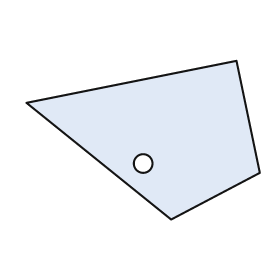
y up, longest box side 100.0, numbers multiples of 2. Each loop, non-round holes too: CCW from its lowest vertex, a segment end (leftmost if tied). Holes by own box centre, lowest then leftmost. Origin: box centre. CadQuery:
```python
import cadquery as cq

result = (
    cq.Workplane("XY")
    .moveTo(12.0, -34.0)
    .lineTo(50.0, -14.0)
    .lineTo(40.0, 34.0)
    .lineTo(-50.0, 16.0)
    .close()
    .moveTo(0.0, -10.0)
    .circle(4.0)
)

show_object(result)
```